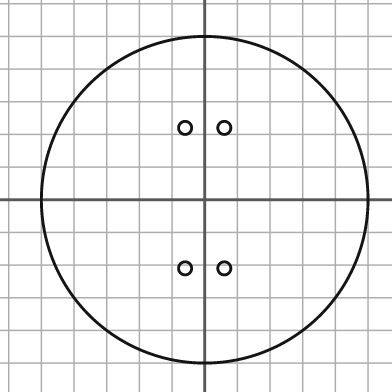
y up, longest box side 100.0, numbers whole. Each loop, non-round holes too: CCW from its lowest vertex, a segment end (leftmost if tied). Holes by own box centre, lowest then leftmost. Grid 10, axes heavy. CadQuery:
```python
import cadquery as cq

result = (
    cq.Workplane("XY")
    .moveTo(0.0, 0.0)
    .circle(50.0)
    .moveTo(-6.0, -21.0)
    .circle(2.0)
    .moveTo(6.0, -21.0)
    .circle(2.0)
    .moveTo(-6.0, 22.0)
    .circle(2.0)
    .moveTo(6.0, 22.0)
    .circle(2.0)
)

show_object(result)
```